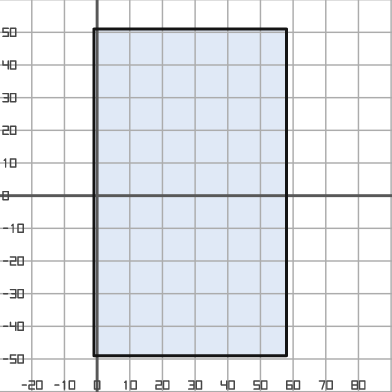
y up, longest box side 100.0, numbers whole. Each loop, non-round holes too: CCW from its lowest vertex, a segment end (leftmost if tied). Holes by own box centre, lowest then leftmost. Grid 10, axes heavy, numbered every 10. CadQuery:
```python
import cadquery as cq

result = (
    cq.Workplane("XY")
    .moveTo(-1.0, -49.0)
    .lineTo(58.0, -49.0)
    .lineTo(58.0, 51.0)
    .lineTo(-1.0, 51.0)
    .close()
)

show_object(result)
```